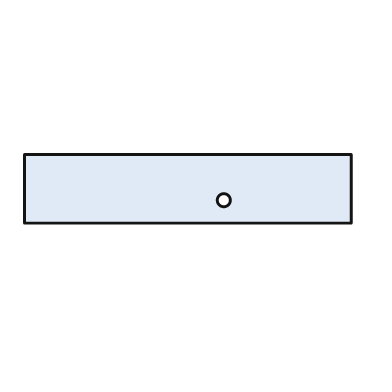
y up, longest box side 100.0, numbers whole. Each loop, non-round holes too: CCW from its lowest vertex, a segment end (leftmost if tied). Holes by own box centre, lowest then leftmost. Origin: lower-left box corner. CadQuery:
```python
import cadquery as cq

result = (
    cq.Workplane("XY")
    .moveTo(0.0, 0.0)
    .lineTo(100.0, 0.0)
    .lineTo(100.0, 21.0)
    .lineTo(0.0, 21.0)
    .close()
    .moveTo(61.0, 7.0)
    .circle(2.0)
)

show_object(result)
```